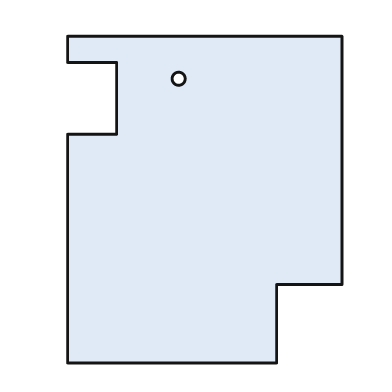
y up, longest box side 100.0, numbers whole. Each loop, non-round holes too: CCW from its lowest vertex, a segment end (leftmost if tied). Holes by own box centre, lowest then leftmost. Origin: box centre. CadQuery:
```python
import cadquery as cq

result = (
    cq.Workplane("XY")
    .moveTo(-42.0, -50.0)
    .lineTo(22.0, -50.0)
    .lineTo(22.0, -26.0)
    .lineTo(42.0, -26.0)
    .lineTo(42.0, 50.0)
    .lineTo(-42.0, 50.0)
    .lineTo(-42.0, 42.0)
    .lineTo(-27.0, 42.0)
    .lineTo(-27.0, 20.0)
    .lineTo(-42.0, 20.0)
    .close()
    .moveTo(-8.0, 37.0)
    .circle(2.0)
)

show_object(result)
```